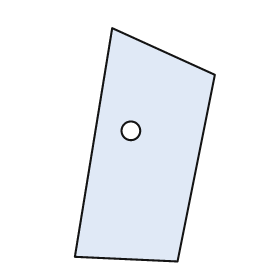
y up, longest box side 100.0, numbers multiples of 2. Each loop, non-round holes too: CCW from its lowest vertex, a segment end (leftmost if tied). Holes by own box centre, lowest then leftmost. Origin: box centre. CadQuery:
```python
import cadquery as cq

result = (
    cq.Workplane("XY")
    .moveTo(14.0, -50.0)
    .lineTo(30.0, 30.0)
    .lineTo(-14.0, 50.0)
    .lineTo(-30.0, -48.0)
    .close()
    .moveTo(-6.0, 6.0)
    .circle(4.0)
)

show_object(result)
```